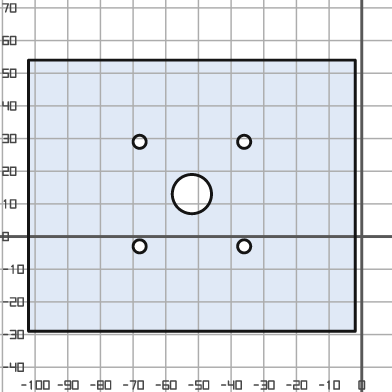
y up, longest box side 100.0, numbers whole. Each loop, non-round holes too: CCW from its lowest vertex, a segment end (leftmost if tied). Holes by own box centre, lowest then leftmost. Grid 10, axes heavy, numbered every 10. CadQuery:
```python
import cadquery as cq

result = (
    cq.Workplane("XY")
    .moveTo(-102.0, -29.0)
    .lineTo(-2.0, -29.0)
    .lineTo(-2.0, 54.0)
    .lineTo(-102.0, 54.0)
    .close()
    .moveTo(-68.0, -3.0)
    .circle(2.0)
    .moveTo(-36.0, -3.0)
    .circle(2.0)
    .moveTo(-52.0, 13.0)
    .circle(6.0)
    .moveTo(-68.0, 29.0)
    .circle(2.0)
    .moveTo(-36.0, 29.0)
    .circle(2.0)
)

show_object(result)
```